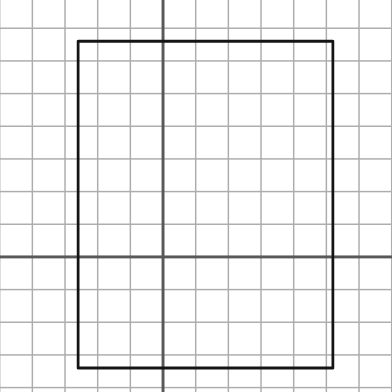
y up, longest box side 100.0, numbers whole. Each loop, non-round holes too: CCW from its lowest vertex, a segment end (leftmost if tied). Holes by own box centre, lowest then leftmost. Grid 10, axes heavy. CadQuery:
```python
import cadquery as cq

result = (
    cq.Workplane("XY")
    .moveTo(-26.0, -34.0)
    .lineTo(52.0, -34.0)
    .lineTo(52.0, 66.0)
    .lineTo(-26.0, 66.0)
    .close()
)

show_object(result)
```